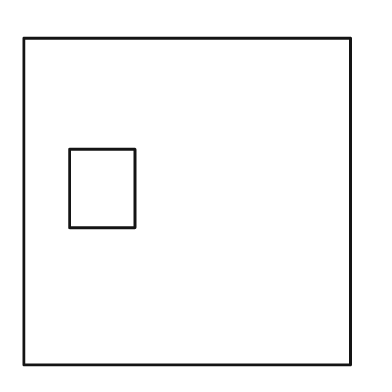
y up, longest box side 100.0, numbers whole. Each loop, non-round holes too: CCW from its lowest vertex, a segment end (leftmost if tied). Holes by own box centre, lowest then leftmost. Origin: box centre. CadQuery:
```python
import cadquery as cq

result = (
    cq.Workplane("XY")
    .moveTo(-50.0, -50.0)
    .lineTo(50.0, -50.0)
    .lineTo(50.0, 50.0)
    .lineTo(-50.0, 50.0)
    .close()
    .moveTo(-36.0, -8.0)
    .lineTo(-16.0, -8.0)
    .lineTo(-16.0, 16.0)
    .lineTo(-36.0, 16.0)
    .close()
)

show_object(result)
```